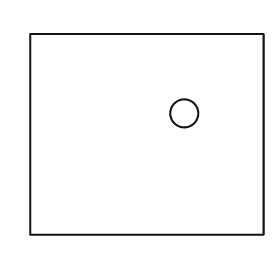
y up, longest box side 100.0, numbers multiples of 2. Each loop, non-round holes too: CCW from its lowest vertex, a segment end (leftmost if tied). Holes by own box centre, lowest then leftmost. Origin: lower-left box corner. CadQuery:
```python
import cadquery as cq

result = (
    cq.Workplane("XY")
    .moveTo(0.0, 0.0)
    .lineTo(100.0, 0.0)
    .lineTo(100.0, 86.0)
    .lineTo(0.0, 86.0)
    .close()
    .moveTo(66.0, 52.0)
    .circle(6.0)
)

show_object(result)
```